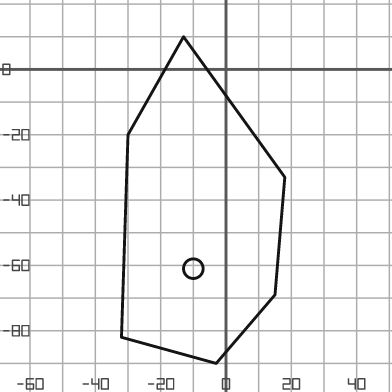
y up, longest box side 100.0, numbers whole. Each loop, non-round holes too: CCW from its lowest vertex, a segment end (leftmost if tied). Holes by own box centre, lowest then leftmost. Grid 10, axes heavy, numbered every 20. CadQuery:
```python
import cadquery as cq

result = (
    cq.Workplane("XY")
    .moveTo(-3.0, -90.0)
    .lineTo(15.0, -69.0)
    .lineTo(18.0, -33.0)
    .lineTo(-13.0, 10.0)
    .lineTo(-30.0, -20.0)
    .lineTo(-32.0, -82.0)
    .close()
    .moveTo(-10.0, -61.0)
    .circle(3.0)
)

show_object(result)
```